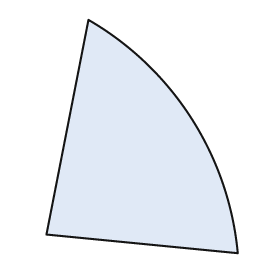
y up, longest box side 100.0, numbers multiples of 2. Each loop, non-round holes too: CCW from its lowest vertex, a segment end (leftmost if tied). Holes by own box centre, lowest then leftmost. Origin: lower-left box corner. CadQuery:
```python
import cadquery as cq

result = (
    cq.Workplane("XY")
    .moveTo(82.0, 0.0)
    .threePointArc((62.0, 58.0), (18.0, 100.0))
    .lineTo(0.0, 8.0)
    .close()
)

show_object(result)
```